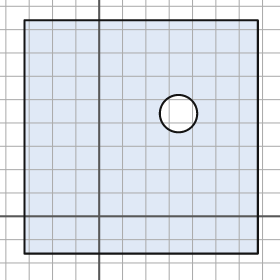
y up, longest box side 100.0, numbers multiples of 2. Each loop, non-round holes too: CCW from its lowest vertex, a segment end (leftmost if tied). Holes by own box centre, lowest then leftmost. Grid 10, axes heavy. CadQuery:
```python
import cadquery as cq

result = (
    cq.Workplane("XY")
    .moveTo(-32.0, -16.0)
    .lineTo(68.0, -16.0)
    .lineTo(68.0, 84.0)
    .lineTo(-32.0, 84.0)
    .close()
    .moveTo(34.0, 44.0)
    .circle(8.0)
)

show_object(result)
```